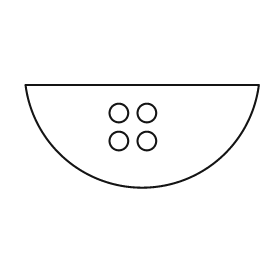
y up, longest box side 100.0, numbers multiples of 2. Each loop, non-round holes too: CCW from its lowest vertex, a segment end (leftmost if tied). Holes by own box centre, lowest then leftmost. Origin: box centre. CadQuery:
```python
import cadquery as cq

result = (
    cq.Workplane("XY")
    .moveTo(-50.0, 22.0)
    .threePointArc((0.0, -22.0), (50.0, 22.0))
    .close()
    .moveTo(-10.0, -2.0)
    .circle(4.0)
    .moveTo(2.0, -2.0)
    .circle(4.0)
    .moveTo(-10.0, 10.0)
    .circle(4.0)
    .moveTo(2.0, 10.0)
    .circle(4.0)
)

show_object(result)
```